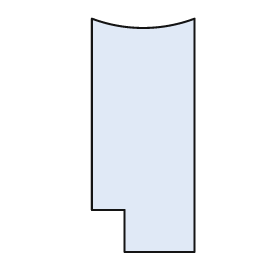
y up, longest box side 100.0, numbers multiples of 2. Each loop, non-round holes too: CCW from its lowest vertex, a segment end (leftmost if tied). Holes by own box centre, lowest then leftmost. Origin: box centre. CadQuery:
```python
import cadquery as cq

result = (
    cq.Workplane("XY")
    .moveTo(-8.0, -50.0)
    .lineTo(22.0, -50.0)
    .lineTo(22.0, 50.0)
    .threePointArc((0.0, 46.0), (-22.0, 50.0))
    .lineTo(-22.0, -32.0)
    .lineTo(-8.0, -32.0)
    .close()
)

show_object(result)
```